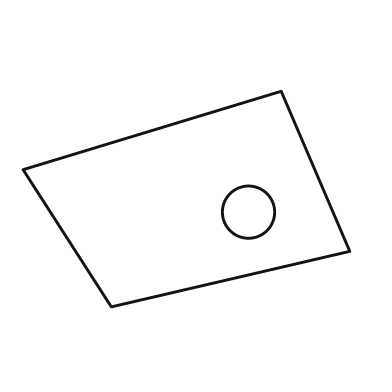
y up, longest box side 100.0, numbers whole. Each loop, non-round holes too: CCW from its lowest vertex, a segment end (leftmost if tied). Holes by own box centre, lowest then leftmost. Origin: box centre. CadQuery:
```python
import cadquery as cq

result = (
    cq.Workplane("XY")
    .moveTo(-23.0, -33.0)
    .lineTo(50.0, -16.0)
    .lineTo(29.0, 33.0)
    .lineTo(-50.0, 9.0)
    .close()
    .moveTo(19.0, -4.0)
    .circle(8.0)
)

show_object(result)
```